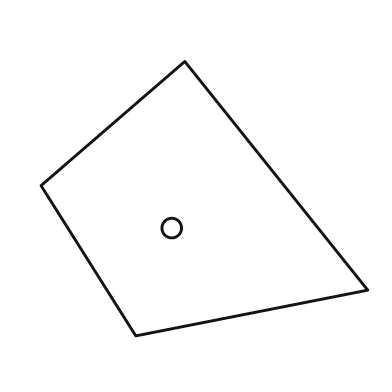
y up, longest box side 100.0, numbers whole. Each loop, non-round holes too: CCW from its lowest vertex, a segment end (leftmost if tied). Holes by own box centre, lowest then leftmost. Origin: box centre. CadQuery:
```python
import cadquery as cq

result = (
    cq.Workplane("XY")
    .moveTo(-21.0, -42.0)
    .lineTo(50.0, -28.0)
    .lineTo(-6.0, 42.0)
    .lineTo(-50.0, 4.0)
    .close()
    .moveTo(-10.0, -9.0)
    .circle(3.0)
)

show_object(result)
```